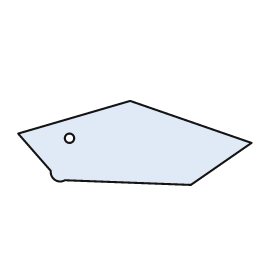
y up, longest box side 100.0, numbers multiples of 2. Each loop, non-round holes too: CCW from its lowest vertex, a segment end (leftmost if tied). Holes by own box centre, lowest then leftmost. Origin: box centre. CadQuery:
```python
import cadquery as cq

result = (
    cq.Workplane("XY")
    .moveTo(24.0, -18.0)
    .lineTo(50.0, 0.0)
    .lineTo(-2.0, 18.0)
    .lineTo(-50.0, 4.0)
    .lineTo(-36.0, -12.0)
    .threePointArc((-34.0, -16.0), (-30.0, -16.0))
    .close()
    .moveTo(-28.0, 2.0)
    .circle(2.0)
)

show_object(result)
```